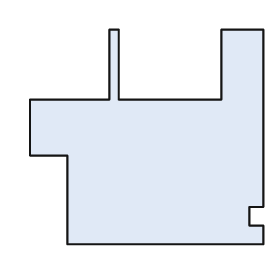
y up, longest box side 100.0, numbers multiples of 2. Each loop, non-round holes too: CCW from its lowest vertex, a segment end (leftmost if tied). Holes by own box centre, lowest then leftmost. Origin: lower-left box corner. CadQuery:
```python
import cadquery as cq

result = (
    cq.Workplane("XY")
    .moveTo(16.0, 0.0)
    .lineTo(100.0, 0.0)
    .lineTo(100.0, 8.0)
    .lineTo(94.0, 8.0)
    .lineTo(94.0, 16.0)
    .lineTo(100.0, 16.0)
    .lineTo(100.0, 92.0)
    .lineTo(82.0, 92.0)
    .lineTo(82.0, 62.0)
    .lineTo(38.0, 62.0)
    .lineTo(38.0, 92.0)
    .lineTo(34.0, 92.0)
    .lineTo(34.0, 62.0)
    .lineTo(0.0, 62.0)
    .lineTo(0.0, 38.0)
    .lineTo(16.0, 38.0)
    .close()
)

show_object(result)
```